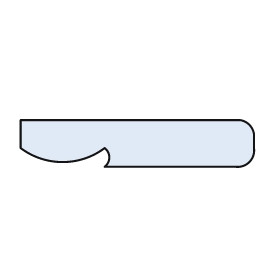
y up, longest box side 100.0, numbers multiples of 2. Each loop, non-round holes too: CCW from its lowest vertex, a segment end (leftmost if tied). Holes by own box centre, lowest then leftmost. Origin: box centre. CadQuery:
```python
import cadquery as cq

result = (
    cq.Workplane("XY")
    .moveTo(-14.0, -10.0)
    .lineTo(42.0, -10.0)
    .threePointArc((48.0, -8.0), (50.0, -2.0))
    .lineTo(50.0, 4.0)
    .threePointArc((48.0, 8.0), (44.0, 10.0))
    .lineTo(-50.0, 10.0)
    .lineTo(-50.0, -2.0)
    .threePointArc((-32.0, -8.0), (-14.0, -2.0))
    .threePointArc((-12.0, -6.0), (-14.0, -10.0))
    .close()
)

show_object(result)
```